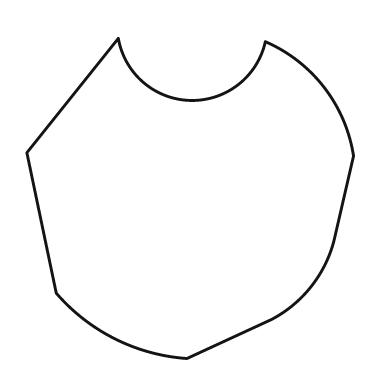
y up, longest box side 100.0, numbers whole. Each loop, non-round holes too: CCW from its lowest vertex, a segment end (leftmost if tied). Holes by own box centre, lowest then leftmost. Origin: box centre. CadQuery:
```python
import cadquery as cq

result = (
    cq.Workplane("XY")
    .moveTo(-1.0, -49.0)
    .lineTo(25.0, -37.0)
    .threePointArc((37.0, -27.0), (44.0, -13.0))
    .lineTo(50.0, 13.0)
    .threePointArc((41.0, 34.0), (23.0, 48.0))
    .threePointArc((0.0, 30.0), (-22.0, 49.0))
    .lineTo(-50.0, 14.0)
    .lineTo(-41.0, -29.0)
    .threePointArc((-23.0, -43.0), (-1.0, -49.0))
    .close()
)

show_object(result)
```